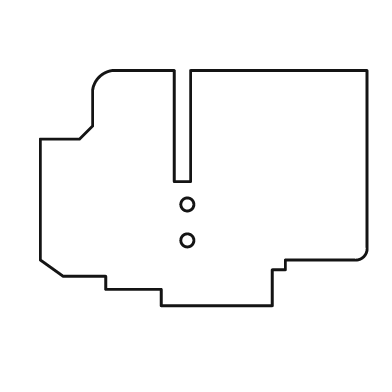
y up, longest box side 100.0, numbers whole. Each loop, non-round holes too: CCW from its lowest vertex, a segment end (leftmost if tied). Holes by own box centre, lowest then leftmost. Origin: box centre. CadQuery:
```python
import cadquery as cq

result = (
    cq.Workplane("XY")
    .moveTo(-13.0, -36.0)
    .lineTo(21.0, -36.0)
    .lineTo(21.0, -25.0)
    .lineTo(25.0, -25.0)
    .lineTo(25.0, -22.0)
    .lineTo(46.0, -22.0)
    .threePointArc((49.0, -21.0), (50.0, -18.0))
    .lineTo(50.0, 36.0)
    .lineTo(-4.0, 36.0)
    .lineTo(-4.0, 2.0)
    .lineTo(-9.0, 2.0)
    .lineTo(-9.0, 36.0)
    .lineTo(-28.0, 36.0)
    .threePointArc((-32.0, 34.0), (-34.0, 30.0))
    .lineTo(-34.0, 19.0)
    .lineTo(-38.0, 15.0)
    .lineTo(-50.0, 15.0)
    .lineTo(-50.0, -22.0)
    .lineTo(-43.0, -27.0)
    .lineTo(-30.0, -27.0)
    .lineTo(-30.0, -31.0)
    .lineTo(-13.0, -31.0)
    .close()
    .moveTo(-5.0, -16.0)
    .circle(2.0)
    .moveTo(-5.0, -5.0)
    .circle(2.0)
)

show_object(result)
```